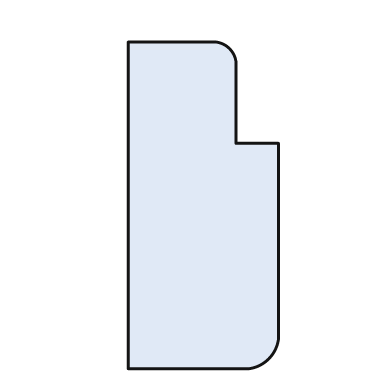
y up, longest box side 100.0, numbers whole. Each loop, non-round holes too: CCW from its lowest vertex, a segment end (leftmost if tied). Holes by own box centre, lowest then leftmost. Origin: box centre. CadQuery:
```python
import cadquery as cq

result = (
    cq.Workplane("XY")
    .moveTo(-23.0, -50.0)
    .lineTo(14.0, -50.0)
    .threePointArc((20.0, -47.0), (23.0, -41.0))
    .lineTo(23.0, 19.0)
    .lineTo(10.0, 19.0)
    .lineTo(10.0, 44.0)
    .threePointArc((8.0, 48.0), (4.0, 50.0))
    .lineTo(-23.0, 50.0)
    .close()
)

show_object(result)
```